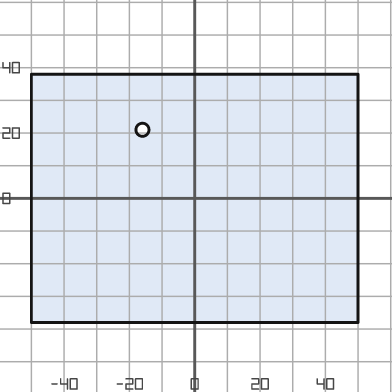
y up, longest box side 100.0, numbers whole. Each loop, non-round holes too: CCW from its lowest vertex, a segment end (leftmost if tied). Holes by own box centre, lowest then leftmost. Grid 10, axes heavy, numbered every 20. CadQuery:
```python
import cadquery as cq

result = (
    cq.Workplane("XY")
    .moveTo(-50.0, -38.0)
    .lineTo(50.0, -38.0)
    .lineTo(50.0, 38.0)
    .lineTo(-50.0, 38.0)
    .close()
    .moveTo(-16.0, 21.0)
    .circle(2.0)
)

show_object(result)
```